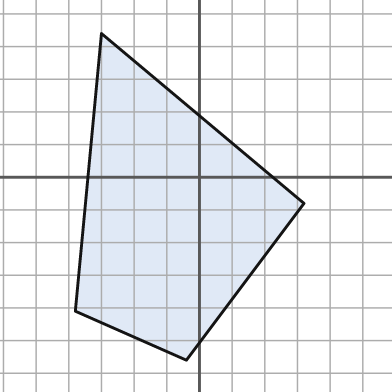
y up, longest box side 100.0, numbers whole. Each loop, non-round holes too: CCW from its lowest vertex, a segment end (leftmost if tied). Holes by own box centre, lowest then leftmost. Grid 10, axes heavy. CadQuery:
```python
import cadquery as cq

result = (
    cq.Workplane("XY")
    .moveTo(-4.0, -56.0)
    .lineTo(32.0, -8.0)
    .lineTo(-30.0, 44.0)
    .lineTo(-38.0, -41.0)
    .close()
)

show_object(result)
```